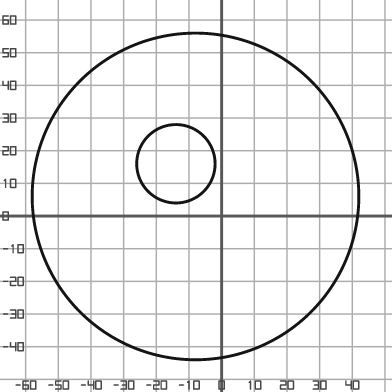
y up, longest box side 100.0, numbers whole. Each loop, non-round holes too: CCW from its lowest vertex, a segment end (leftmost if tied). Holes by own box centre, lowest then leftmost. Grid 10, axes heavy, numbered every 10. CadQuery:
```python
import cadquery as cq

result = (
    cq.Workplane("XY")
    .moveTo(-8.0, 6.0)
    .circle(50.0)
    .moveTo(-14.0, 16.0)
    .circle(12.0)
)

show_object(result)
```